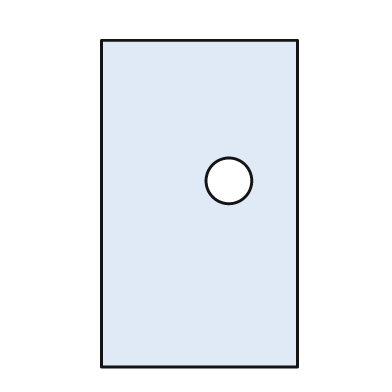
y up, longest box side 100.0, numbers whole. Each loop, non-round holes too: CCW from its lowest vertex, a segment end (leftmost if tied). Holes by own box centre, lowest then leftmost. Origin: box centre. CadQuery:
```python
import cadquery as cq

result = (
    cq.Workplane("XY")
    .moveTo(-30.0, -50.0)
    .lineTo(30.0, -50.0)
    .lineTo(30.0, 50.0)
    .lineTo(-30.0, 50.0)
    .close()
    .moveTo(9.0, 7.0)
    .circle(7.0)
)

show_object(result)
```